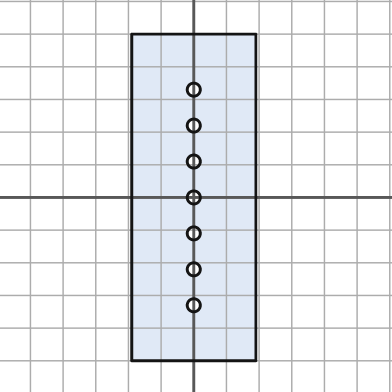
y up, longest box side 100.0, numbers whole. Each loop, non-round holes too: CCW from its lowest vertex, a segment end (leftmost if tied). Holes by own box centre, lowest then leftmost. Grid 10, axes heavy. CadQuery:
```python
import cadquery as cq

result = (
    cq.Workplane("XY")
    .moveTo(-19.0, -50.0)
    .lineTo(19.0, -50.0)
    .lineTo(19.0, 50.0)
    .lineTo(-19.0, 50.0)
    .close()
    .moveTo(0.0, -33.0)
    .circle(2.0)
    .moveTo(0.0, -22.0)
    .circle(2.0)
    .moveTo(0.0, -11.0)
    .circle(2.0)
    .moveTo(0.0, 0.0)
    .circle(2.0)
    .moveTo(0.0, 11.0)
    .circle(2.0)
    .moveTo(0.0, 22.0)
    .circle(2.0)
    .moveTo(0.0, 33.0)
    .circle(2.0)
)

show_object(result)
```